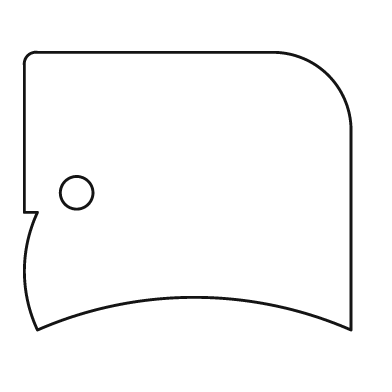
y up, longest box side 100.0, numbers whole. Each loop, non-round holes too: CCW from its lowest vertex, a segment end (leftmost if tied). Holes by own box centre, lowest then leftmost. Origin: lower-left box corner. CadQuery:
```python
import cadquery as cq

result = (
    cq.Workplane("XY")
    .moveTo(4.0, 0.0)
    .threePointArc((52.0, 10.0), (100.0, 0.0))
    .lineTo(100.0, 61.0)
    .threePointArc((93.0, 78.0), (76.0, 85.0))
    .lineTo(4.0, 85.0)
    .threePointArc((1.0, 84.0), (0.0, 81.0))
    .lineTo(0.0, 36.0)
    .lineTo(4.0, 36.0)
    .threePointArc((0.0, 18.0), (4.0, 0.0))
    .close()
    .moveTo(16.0, 42.0)
    .circle(5.0)
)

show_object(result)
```